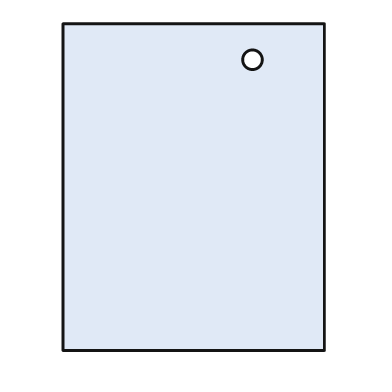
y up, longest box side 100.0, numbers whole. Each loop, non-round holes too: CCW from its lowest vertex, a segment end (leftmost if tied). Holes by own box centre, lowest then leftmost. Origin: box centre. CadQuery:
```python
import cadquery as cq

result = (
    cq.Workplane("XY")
    .moveTo(-40.0, -50.0)
    .lineTo(40.0, -50.0)
    .lineTo(40.0, 50.0)
    .lineTo(-40.0, 50.0)
    .close()
    .moveTo(18.0, 39.0)
    .circle(3.0)
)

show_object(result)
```